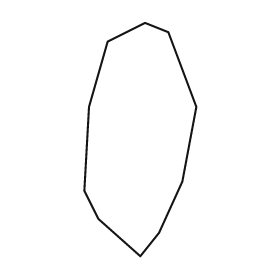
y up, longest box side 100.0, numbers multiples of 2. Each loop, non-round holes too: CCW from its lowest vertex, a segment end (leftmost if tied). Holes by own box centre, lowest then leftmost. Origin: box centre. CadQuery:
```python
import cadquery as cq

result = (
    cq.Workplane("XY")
    .moveTo(0.0, -50.0)
    .lineTo(8.0, -40.0)
    .lineTo(18.0, -18.0)
    .lineTo(24.0, 14.0)
    .lineTo(12.0, 46.0)
    .lineTo(2.0, 50.0)
    .lineTo(-14.0, 42.0)
    .lineTo(-22.0, 14.0)
    .lineTo(-24.0, -22.0)
    .lineTo(-18.0, -34.0)
    .close()
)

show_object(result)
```